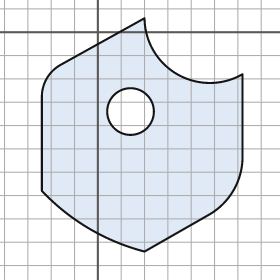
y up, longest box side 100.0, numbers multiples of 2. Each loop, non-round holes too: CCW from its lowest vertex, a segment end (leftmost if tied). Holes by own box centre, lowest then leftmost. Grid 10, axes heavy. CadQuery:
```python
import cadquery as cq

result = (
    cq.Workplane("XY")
    .moveTo(20.0, -94.0)
    .lineTo(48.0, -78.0)
    .threePointArc((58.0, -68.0), (62.0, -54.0))
    .lineTo(62.0, -18.0)
    .threePointArc((34.0, -18.0), (20.0, 6.0))
    .lineTo(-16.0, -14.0)
    .threePointArc((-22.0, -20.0), (-24.0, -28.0))
    .lineTo(-24.0, -68.0)
    .threePointArc((-4.0, -84.0), (20.0, -94.0))
    .close()
    .moveTo(14.0, -34.0)
    .circle(10.0)
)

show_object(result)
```